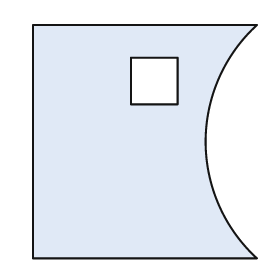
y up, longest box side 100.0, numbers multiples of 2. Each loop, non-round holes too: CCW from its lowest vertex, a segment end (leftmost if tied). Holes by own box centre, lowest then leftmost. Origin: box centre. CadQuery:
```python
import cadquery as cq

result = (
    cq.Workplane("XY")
    .moveTo(-48.0, -50.0)
    .lineTo(48.0, -50.0)
    .threePointArc((26.0, 0.0), (48.0, 50.0))
    .lineTo(-48.0, 50.0)
    .close()
    .moveTo(-6.0, 16.0)
    .lineTo(14.0, 16.0)
    .lineTo(14.0, 36.0)
    .lineTo(-6.0, 36.0)
    .close()
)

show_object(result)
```